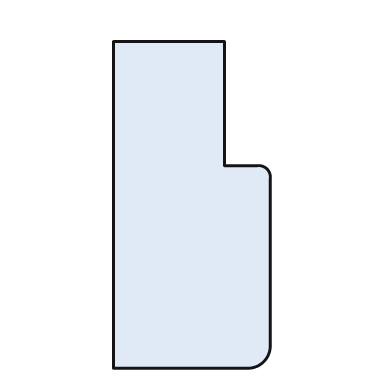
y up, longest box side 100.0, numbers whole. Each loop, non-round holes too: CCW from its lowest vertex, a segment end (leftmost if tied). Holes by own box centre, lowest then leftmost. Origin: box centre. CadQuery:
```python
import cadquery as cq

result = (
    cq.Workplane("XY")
    .moveTo(-24.0, -50.0)
    .lineTo(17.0, -50.0)
    .threePointArc((22.0, -48.0), (24.0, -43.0))
    .lineTo(24.0, 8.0)
    .threePointArc((23.0, 11.0), (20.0, 12.0))
    .lineTo(10.0, 12.0)
    .lineTo(10.0, 50.0)
    .lineTo(-24.0, 50.0)
    .close()
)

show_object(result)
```